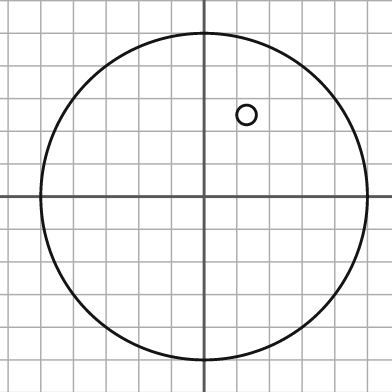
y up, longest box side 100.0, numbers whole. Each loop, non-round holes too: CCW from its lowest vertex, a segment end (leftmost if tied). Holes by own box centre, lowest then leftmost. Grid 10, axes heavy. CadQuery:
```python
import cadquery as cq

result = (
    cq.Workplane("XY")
    .moveTo(0.0, 0.0)
    .circle(50.0)
    .moveTo(13.0, 25.0)
    .circle(3.0)
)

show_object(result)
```